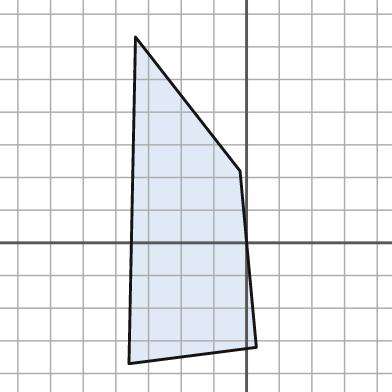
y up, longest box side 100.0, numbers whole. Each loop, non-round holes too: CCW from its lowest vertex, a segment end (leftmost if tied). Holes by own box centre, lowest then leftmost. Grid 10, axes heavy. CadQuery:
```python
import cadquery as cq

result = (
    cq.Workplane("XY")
    .moveTo(-36.0, -37.0)
    .lineTo(3.0, -32.0)
    .lineTo(-2.0, 22.0)
    .lineTo(-34.0, 63.0)
    .close()
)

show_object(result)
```